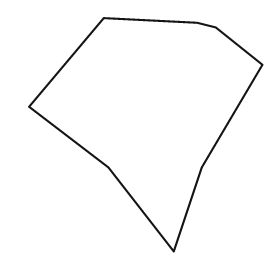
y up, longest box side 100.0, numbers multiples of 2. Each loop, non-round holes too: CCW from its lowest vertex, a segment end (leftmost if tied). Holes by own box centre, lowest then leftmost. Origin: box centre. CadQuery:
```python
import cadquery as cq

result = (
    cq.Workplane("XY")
    .moveTo(12.0, -50.0)
    .lineTo(24.0, -14.0)
    .lineTo(50.0, 30.0)
    .lineTo(30.0, 46.0)
    .lineTo(22.0, 48.0)
    .lineTo(-18.0, 50.0)
    .lineTo(-50.0, 12.0)
    .lineTo(-16.0, -14.0)
    .close()
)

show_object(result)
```